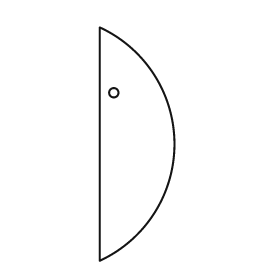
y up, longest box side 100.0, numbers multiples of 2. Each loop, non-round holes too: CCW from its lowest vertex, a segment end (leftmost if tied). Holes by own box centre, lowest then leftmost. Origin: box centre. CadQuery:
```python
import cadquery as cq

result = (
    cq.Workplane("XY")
    .moveTo(-16.0, -50.0)
    .threePointArc((16.0, 0.0), (-16.0, 50.0))
    .close()
    .moveTo(-10.0, 22.0)
    .circle(2.0)
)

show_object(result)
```